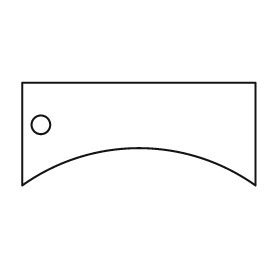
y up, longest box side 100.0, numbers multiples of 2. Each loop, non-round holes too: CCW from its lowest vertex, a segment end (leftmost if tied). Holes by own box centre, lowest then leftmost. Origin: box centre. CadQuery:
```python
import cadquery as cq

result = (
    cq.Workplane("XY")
    .moveTo(-50.0, -22.0)
    .threePointArc((0.0, -6.0), (50.0, -22.0))
    .lineTo(50.0, 22.0)
    .lineTo(-50.0, 22.0)
    .close()
    .moveTo(-42.0, 4.0)
    .circle(4.0)
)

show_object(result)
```